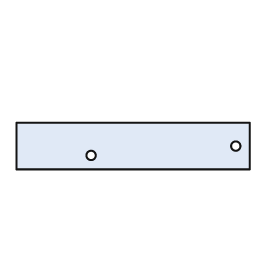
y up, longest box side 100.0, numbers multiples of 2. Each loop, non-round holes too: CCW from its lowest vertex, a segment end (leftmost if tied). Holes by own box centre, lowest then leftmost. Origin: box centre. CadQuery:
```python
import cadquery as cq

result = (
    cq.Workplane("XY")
    .moveTo(-50.0, -10.0)
    .lineTo(50.0, -10.0)
    .lineTo(50.0, 10.0)
    .lineTo(-50.0, 10.0)
    .close()
    .moveTo(-18.0, -4.0)
    .circle(2.0)
    .moveTo(44.0, 0.0)
    .circle(2.0)
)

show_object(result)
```